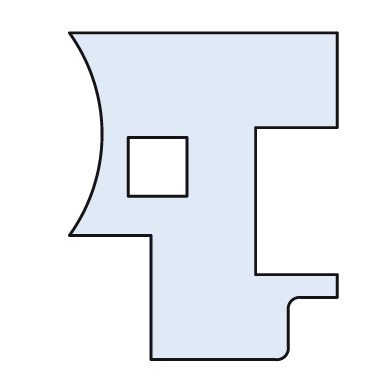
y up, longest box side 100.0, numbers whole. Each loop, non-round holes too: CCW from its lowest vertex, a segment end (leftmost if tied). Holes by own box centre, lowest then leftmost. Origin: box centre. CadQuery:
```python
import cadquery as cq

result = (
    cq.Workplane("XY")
    .moveTo(-16.0, -50.0)
    .lineTo(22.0, -50.0)
    .threePointArc((25.0, -49.0), (26.0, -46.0))
    .lineTo(26.0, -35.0)
    .threePointArc((27.0, -32.0), (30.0, -31.0))
    .lineTo(41.0, -31.0)
    .lineTo(41.0, -24.0)
    .lineTo(16.0, -24.0)
    .lineTo(16.0, 21.0)
    .lineTo(41.0, 21.0)
    .lineTo(41.0, 50.0)
    .lineTo(-41.0, 50.0)
    .threePointArc((-31.0, 19.0), (-41.0, -12.0))
    .lineTo(-16.0, -12.0)
    .close()
    .moveTo(-23.0, 0.0)
    .lineTo(-5.0, 0.0)
    .lineTo(-5.0, 18.0)
    .lineTo(-23.0, 18.0)
    .close()
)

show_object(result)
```